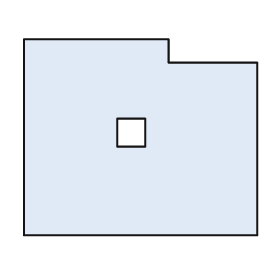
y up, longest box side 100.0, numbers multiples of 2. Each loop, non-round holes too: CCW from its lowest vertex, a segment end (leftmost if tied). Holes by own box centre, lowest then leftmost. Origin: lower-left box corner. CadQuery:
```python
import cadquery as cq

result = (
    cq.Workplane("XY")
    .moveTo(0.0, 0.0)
    .lineTo(100.0, 0.0)
    .lineTo(100.0, 74.0)
    .lineTo(62.0, 74.0)
    .lineTo(62.0, 84.0)
    .lineTo(0.0, 84.0)
    .close()
    .moveTo(40.0, 38.0)
    .lineTo(52.0, 38.0)
    .lineTo(52.0, 50.0)
    .lineTo(40.0, 50.0)
    .close()
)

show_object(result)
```